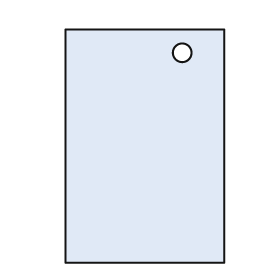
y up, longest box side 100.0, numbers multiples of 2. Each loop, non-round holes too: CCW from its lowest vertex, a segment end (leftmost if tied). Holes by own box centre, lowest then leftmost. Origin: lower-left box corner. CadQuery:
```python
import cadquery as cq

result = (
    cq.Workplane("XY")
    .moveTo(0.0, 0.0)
    .lineTo(68.0, 0.0)
    .lineTo(68.0, 100.0)
    .lineTo(0.0, 100.0)
    .close()
    .moveTo(50.0, 90.0)
    .circle(4.0)
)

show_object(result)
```